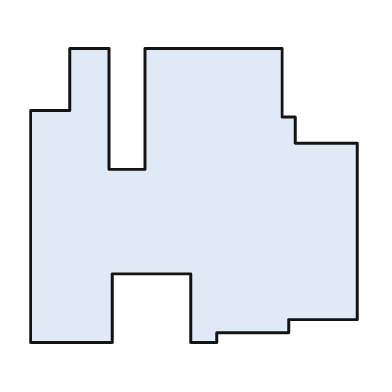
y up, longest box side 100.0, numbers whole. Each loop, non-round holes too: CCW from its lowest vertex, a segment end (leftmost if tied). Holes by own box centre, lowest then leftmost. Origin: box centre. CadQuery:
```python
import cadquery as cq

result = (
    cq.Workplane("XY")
    .moveTo(-50.0, -45.0)
    .lineTo(-25.0, -45.0)
    .lineTo(-25.0, -24.0)
    .lineTo(-1.0, -24.0)
    .lineTo(-1.0, -45.0)
    .lineTo(7.0, -45.0)
    .lineTo(7.0, -42.0)
    .lineTo(29.0, -42.0)
    .lineTo(29.0, -38.0)
    .lineTo(50.0, -38.0)
    .lineTo(50.0, 16.0)
    .lineTo(31.0, 16.0)
    .lineTo(31.0, 24.0)
    .lineTo(27.0, 24.0)
    .lineTo(27.0, 45.0)
    .lineTo(-15.0, 45.0)
    .lineTo(-15.0, 8.0)
    .lineTo(-26.0, 8.0)
    .lineTo(-26.0, 45.0)
    .lineTo(-38.0, 45.0)
    .lineTo(-38.0, 26.0)
    .lineTo(-50.0, 26.0)
    .close()
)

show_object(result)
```